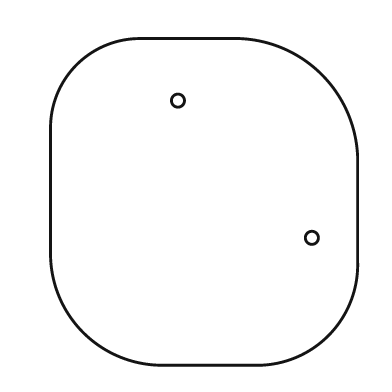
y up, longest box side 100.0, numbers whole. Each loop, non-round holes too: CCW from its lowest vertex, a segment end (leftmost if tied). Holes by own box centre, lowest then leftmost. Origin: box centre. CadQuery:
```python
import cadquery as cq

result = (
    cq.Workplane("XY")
    .moveTo(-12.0, -50.0)
    .lineTo(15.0, -50.0)
    .threePointArc((38.0, -41.0), (47.0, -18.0))
    .lineTo(47.0, 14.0)
    .threePointArc((36.0, 39.0), (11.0, 50.0))
    .lineTo(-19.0, 50.0)
    .threePointArc((-39.0, 42.0), (-47.0, 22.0))
    .lineTo(-47.0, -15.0)
    .threePointArc((-37.0, -40.0), (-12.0, -50.0))
    .close()
    .moveTo(33.0, -11.0)
    .circle(2.0)
    .moveTo(-8.0, 31.0)
    .circle(2.0)
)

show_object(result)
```